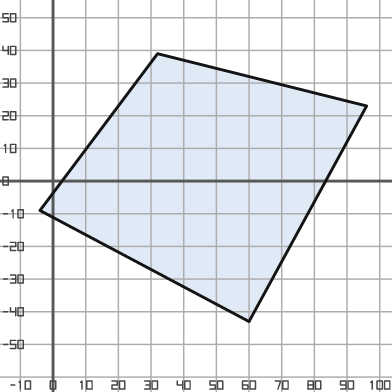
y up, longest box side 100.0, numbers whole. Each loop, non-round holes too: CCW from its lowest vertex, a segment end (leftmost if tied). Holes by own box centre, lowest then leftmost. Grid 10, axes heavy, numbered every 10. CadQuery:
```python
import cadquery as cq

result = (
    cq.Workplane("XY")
    .moveTo(60.0, -43.0)
    .lineTo(96.0, 23.0)
    .lineTo(32.0, 39.0)
    .lineTo(-4.0, -9.0)
    .close()
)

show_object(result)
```